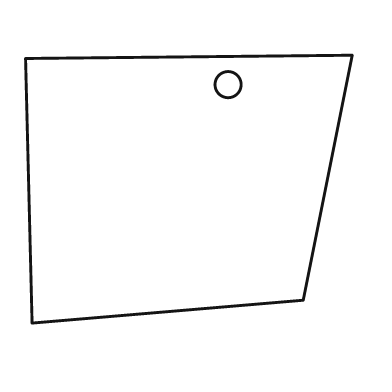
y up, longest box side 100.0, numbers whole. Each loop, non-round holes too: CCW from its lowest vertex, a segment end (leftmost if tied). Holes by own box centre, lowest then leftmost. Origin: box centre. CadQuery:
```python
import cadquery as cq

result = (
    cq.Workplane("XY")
    .moveTo(-48.0, -41.0)
    .lineTo(35.0, -34.0)
    .lineTo(50.0, 41.0)
    .lineTo(-50.0, 40.0)
    .close()
    .moveTo(12.0, 32.0)
    .circle(4.0)
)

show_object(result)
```